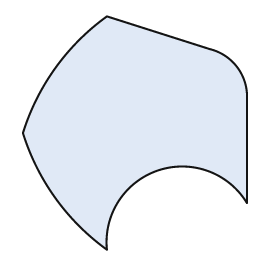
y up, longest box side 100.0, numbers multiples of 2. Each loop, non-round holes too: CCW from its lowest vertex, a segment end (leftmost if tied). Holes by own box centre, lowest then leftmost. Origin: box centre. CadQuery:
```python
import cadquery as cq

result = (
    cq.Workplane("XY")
    .moveTo(-12.0, -50.0)
    .threePointArc((10.0, -16.0), (48.0, -30.0))
    .lineTo(48.0, 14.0)
    .threePointArc((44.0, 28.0), (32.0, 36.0))
    .lineTo(-12.0, 50.0)
    .threePointArc((-34.0, 28.0), (-48.0, 0.0))
    .threePointArc((-34.0, -28.0), (-12.0, -50.0))
    .close()
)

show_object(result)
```